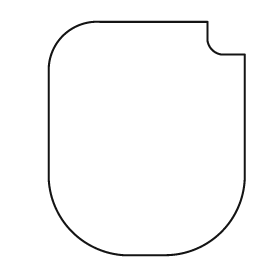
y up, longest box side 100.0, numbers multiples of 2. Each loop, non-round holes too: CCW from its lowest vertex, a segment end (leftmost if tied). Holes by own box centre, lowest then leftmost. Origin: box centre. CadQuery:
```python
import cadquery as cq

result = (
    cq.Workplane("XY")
    .moveTo(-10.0, -50.0)
    .lineTo(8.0, -50.0)
    .threePointArc((32.0, -40.0), (42.0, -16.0))
    .lineTo(42.0, 36.0)
    .lineTo(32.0, 36.0)
    .threePointArc((28.0, 38.0), (26.0, 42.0))
    .lineTo(26.0, 50.0)
    .lineTo(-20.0, 50.0)
    .threePointArc((-36.0, 44.0), (-42.0, 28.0))
    .lineTo(-42.0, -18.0)
    .threePointArc((-32.0, -40.0), (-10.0, -50.0))
    .close()
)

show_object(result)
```